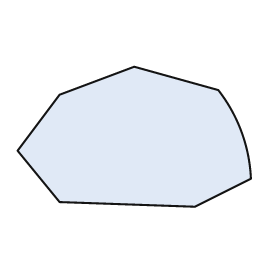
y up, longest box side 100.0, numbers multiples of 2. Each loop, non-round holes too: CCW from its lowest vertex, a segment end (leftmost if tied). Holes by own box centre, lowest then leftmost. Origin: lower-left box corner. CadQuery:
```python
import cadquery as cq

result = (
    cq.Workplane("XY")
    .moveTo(76.0, 0.0)
    .lineTo(100.0, 12.0)
    .threePointArc((96.0, 32.0), (86.0, 50.0))
    .lineTo(50.0, 60.0)
    .lineTo(18.0, 48.0)
    .lineTo(0.0, 24.0)
    .lineTo(18.0, 2.0)
    .close()
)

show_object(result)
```